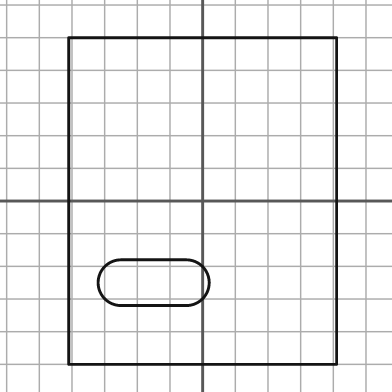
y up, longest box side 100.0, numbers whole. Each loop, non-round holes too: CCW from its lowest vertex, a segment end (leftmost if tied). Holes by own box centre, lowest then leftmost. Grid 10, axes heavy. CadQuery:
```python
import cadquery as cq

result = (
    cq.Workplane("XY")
    .moveTo(-41.0, -50.0)
    .lineTo(41.0, -50.0)
    .lineTo(41.0, 50.0)
    .lineTo(-41.0, 50.0)
    .close()
    .moveTo(-25.0, -32.0)
    .lineTo(-5.0, -32.0)
    .threePointArc((2.0, -25.0), (-5.0, -18.0))
    .lineTo(-25.0, -18.0)
    .threePointArc((-32.0, -25.0), (-25.0, -32.0))
    .close()
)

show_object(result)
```